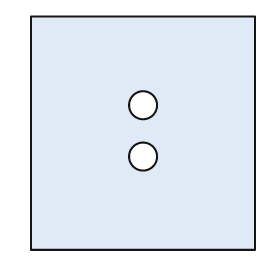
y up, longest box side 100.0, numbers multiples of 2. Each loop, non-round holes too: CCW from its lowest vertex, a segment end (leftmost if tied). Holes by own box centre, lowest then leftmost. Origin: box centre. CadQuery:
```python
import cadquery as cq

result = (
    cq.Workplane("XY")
    .moveTo(-48.0, -50.0)
    .lineTo(48.0, -50.0)
    .lineTo(48.0, 50.0)
    .lineTo(-48.0, 50.0)
    .close()
    .moveTo(0.0, -10.0)
    .circle(6.0)
    .moveTo(0.0, 12.0)
    .circle(6.0)
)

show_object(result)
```